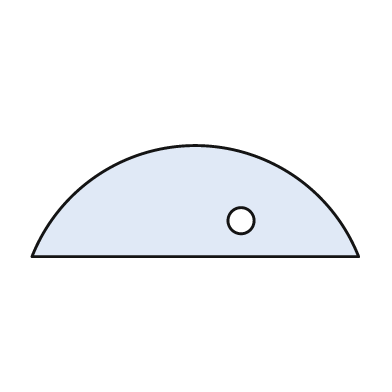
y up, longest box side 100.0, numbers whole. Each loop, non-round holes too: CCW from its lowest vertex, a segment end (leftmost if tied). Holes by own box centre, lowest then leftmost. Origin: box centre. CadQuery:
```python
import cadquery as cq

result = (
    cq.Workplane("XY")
    .moveTo(-50.0, -17.0)
    .lineTo(50.0, -17.0)
    .threePointArc((0.0, 17.0), (-50.0, -17.0))
    .close()
    .moveTo(14.0, -6.0)
    .circle(4.0)
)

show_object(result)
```